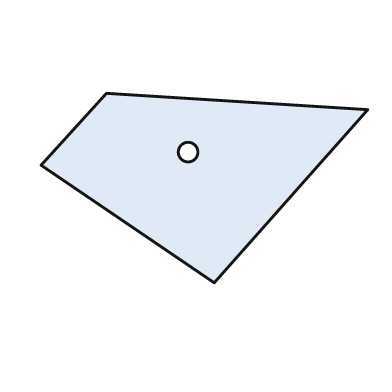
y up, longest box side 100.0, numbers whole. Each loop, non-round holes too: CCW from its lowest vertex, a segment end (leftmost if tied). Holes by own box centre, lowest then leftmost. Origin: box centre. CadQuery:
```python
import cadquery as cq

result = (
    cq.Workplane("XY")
    .moveTo(3.0, -29.0)
    .lineTo(50.0, 24.0)
    .lineTo(-30.0, 29.0)
    .lineTo(-50.0, 7.0)
    .close()
    .moveTo(-5.0, 11.0)
    .circle(3.0)
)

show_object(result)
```